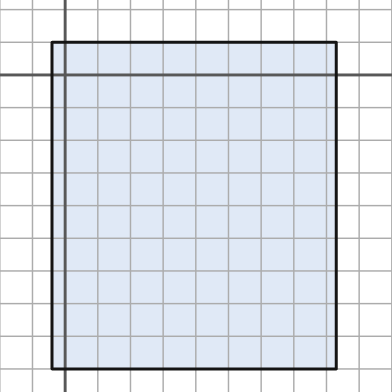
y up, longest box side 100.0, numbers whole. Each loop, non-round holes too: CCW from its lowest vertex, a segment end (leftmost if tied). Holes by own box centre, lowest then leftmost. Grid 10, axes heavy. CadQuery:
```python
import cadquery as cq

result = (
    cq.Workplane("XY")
    .moveTo(-4.0, -90.0)
    .lineTo(83.0, -90.0)
    .lineTo(83.0, 10.0)
    .lineTo(-4.0, 10.0)
    .close()
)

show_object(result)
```